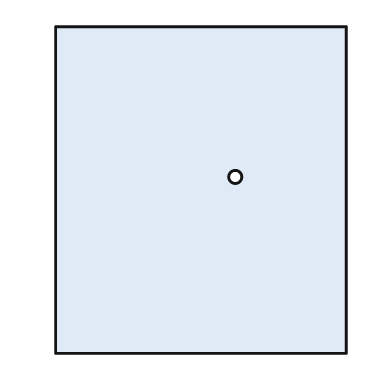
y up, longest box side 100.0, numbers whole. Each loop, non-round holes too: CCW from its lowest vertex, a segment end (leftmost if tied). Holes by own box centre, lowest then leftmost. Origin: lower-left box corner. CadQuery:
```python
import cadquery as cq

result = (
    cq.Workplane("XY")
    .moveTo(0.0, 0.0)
    .lineTo(89.0, 0.0)
    .lineTo(89.0, 100.0)
    .lineTo(0.0, 100.0)
    .close()
    .moveTo(55.0, 54.0)
    .circle(2.0)
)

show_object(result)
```